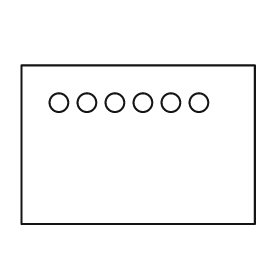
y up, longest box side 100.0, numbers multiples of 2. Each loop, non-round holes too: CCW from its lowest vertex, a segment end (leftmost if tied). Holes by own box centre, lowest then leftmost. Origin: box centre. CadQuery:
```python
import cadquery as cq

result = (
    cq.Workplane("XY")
    .moveTo(-50.0, -34.0)
    .lineTo(50.0, -34.0)
    .lineTo(50.0, 34.0)
    .lineTo(-50.0, 34.0)
    .close()
    .moveTo(-34.0, 18.0)
    .circle(4.0)
    .moveTo(-22.0, 18.0)
    .circle(4.0)
    .moveTo(-10.0, 18.0)
    .circle(4.0)
    .moveTo(2.0, 18.0)
    .circle(4.0)
    .moveTo(14.0, 18.0)
    .circle(4.0)
    .moveTo(26.0, 18.0)
    .circle(4.0)
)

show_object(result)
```